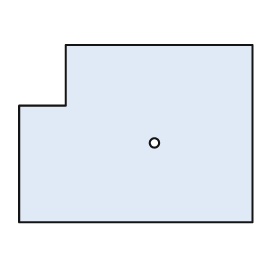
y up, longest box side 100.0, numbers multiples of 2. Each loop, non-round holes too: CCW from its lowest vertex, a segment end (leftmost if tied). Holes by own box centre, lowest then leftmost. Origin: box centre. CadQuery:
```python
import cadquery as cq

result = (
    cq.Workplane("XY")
    .moveTo(-50.0, -38.0)
    .lineTo(50.0, -38.0)
    .lineTo(50.0, 38.0)
    .lineTo(-30.0, 38.0)
    .lineTo(-30.0, 12.0)
    .lineTo(-50.0, 12.0)
    .close()
    .moveTo(8.0, -4.0)
    .circle(2.0)
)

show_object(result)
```